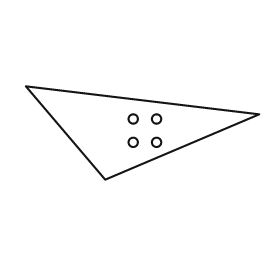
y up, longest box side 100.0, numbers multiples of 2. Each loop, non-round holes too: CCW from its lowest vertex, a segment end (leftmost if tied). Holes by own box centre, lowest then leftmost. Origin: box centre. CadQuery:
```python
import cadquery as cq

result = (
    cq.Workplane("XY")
    .moveTo(-16.0, -20.0)
    .lineTo(50.0, 8.0)
    .lineTo(-50.0, 20.0)
    .close()
    .moveTo(-4.0, -4.0)
    .circle(2.0)
    .moveTo(6.0, -4.0)
    .circle(2.0)
    .moveTo(-4.0, 6.0)
    .circle(2.0)
    .moveTo(6.0, 6.0)
    .circle(2.0)
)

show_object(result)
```